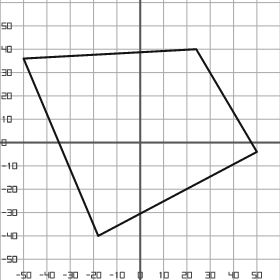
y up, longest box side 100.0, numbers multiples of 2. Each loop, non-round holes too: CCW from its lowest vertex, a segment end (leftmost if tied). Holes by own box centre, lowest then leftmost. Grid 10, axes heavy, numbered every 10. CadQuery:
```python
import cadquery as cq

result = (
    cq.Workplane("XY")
    .moveTo(-18.0, -40.0)
    .lineTo(50.0, -4.0)
    .lineTo(24.0, 40.0)
    .lineTo(-50.0, 36.0)
    .close()
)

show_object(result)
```